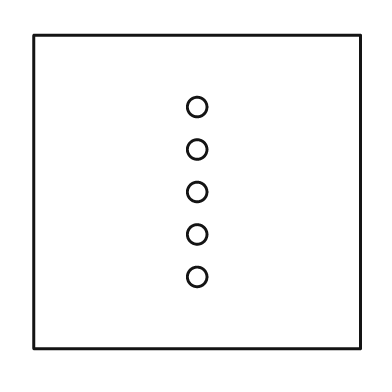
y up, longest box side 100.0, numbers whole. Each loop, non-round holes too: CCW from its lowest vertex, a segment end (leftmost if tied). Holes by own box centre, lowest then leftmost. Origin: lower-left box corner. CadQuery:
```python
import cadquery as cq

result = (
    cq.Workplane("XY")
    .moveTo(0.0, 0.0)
    .lineTo(100.0, 0.0)
    .lineTo(100.0, 96.0)
    .lineTo(0.0, 96.0)
    .close()
    .moveTo(50.0, 22.0)
    .circle(3.0)
    .moveTo(50.0, 35.0)
    .circle(3.0)
    .moveTo(50.0, 48.0)
    .circle(3.0)
    .moveTo(50.0, 61.0)
    .circle(3.0)
    .moveTo(50.0, 74.0)
    .circle(3.0)
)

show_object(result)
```